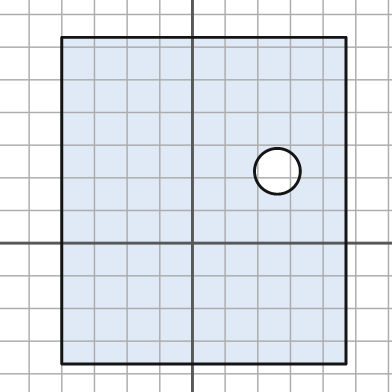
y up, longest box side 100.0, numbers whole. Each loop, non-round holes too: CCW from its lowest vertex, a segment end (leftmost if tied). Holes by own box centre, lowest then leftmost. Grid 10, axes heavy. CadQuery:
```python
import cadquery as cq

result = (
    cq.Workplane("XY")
    .moveTo(-40.0, -37.0)
    .lineTo(47.0, -37.0)
    .lineTo(47.0, 63.0)
    .lineTo(-40.0, 63.0)
    .close()
    .moveTo(26.0, 22.0)
    .circle(7.0)
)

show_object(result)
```